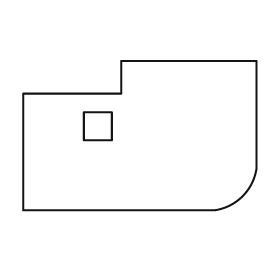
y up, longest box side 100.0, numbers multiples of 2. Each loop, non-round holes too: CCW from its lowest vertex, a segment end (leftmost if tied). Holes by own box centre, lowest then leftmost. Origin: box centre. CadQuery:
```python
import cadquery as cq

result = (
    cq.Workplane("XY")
    .moveTo(-50.0, -32.0)
    .lineTo(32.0, -32.0)
    .threePointArc((44.0, -26.0), (50.0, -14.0))
    .lineTo(50.0, 32.0)
    .lineTo(-8.0, 32.0)
    .lineTo(-8.0, 18.0)
    .lineTo(-50.0, 18.0)
    .close()
    .moveTo(-24.0, -2.0)
    .lineTo(-12.0, -2.0)
    .lineTo(-12.0, 10.0)
    .lineTo(-24.0, 10.0)
    .close()
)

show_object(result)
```